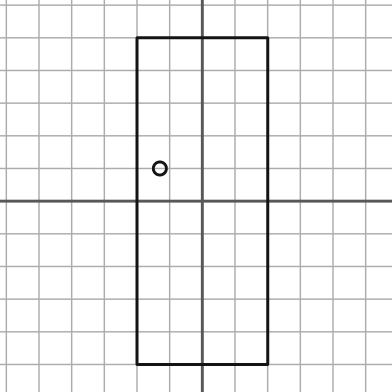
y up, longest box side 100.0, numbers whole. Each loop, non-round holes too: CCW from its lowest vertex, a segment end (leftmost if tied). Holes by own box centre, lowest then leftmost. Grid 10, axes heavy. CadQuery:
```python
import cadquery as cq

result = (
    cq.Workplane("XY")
    .moveTo(-20.0, -50.0)
    .lineTo(20.0, -50.0)
    .lineTo(20.0, 50.0)
    .lineTo(-20.0, 50.0)
    .close()
    .moveTo(-13.0, 10.0)
    .circle(2.0)
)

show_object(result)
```